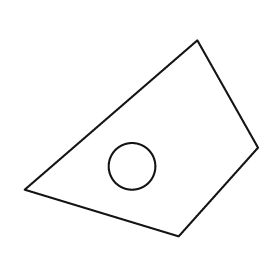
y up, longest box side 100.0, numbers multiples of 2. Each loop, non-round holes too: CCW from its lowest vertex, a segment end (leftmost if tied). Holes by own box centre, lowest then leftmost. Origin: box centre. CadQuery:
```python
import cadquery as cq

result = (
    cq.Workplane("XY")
    .moveTo(16.0, -42.0)
    .lineTo(50.0, -4.0)
    .lineTo(24.0, 42.0)
    .lineTo(-50.0, -22.0)
    .close()
    .moveTo(-4.0, -12.0)
    .circle(10.0)
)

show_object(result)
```